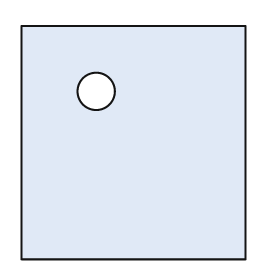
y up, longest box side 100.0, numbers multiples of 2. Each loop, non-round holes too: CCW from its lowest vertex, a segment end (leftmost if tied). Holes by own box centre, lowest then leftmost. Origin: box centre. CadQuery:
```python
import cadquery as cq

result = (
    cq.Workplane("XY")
    .moveTo(-48.0, -50.0)
    .lineTo(48.0, -50.0)
    .lineTo(48.0, 50.0)
    .lineTo(-48.0, 50.0)
    .close()
    .moveTo(-16.0, 22.0)
    .circle(8.0)
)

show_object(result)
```